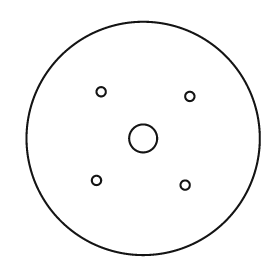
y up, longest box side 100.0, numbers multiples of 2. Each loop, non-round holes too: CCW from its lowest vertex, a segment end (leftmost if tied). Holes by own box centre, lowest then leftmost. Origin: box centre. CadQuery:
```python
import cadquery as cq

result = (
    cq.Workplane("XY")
    .moveTo(0.0, 0.0)
    .circle(50.0)
    .moveTo(18.0, -20.0)
    .circle(2.0)
    .moveTo(-20.0, -18.0)
    .circle(2.0)
    .moveTo(0.0, 0.0)
    .circle(6.0)
    .moveTo(20.0, 18.0)
    .circle(2.0)
    .moveTo(-18.0, 20.0)
    .circle(2.0)
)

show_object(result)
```